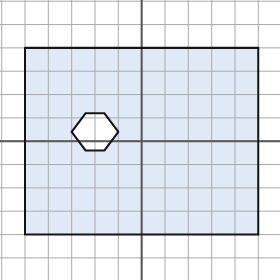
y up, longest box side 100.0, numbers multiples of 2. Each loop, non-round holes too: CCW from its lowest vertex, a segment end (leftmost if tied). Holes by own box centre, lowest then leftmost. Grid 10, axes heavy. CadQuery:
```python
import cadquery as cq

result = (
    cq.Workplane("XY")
    .moveTo(-50.0, -40.0)
    .lineTo(50.0, -40.0)
    .lineTo(50.0, 40.0)
    .lineTo(-50.0, 40.0)
    .close()
    .moveTo(-24.0, -4.0)
    .lineTo(-16.0, -4.0)
    .lineTo(-10.0, 4.0)
    .lineTo(-16.0, 12.0)
    .lineTo(-24.0, 12.0)
    .lineTo(-30.0, 4.0)
    .close()
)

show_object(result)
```